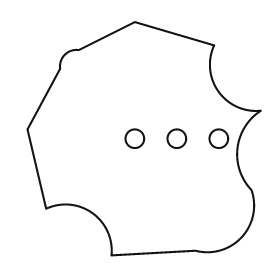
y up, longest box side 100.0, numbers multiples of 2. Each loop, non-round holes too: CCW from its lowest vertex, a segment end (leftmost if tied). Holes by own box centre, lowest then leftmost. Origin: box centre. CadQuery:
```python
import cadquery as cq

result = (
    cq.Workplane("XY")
    .moveTo(-14.0, -50.0)
    .lineTo(22.0, -48.0)
    .threePointArc((42.0, -42.0), (46.0, -22.0))
    .threePointArc((40.0, -4.0), (50.0, 12.0))
    .threePointArc((32.0, 20.0), (30.0, 40.0))
    .lineTo(-4.0, 50.0)
    .lineTo(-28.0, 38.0)
    .threePointArc((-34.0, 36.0), (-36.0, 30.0))
    .lineTo(-50.0, 4.0)
    .lineTo(-42.0, -30.0)
    .threePointArc((-22.0, -32.0), (-14.0, -50.0))
    .close()
    .moveTo(-4.0, 0.0)
    .circle(4.0)
    .moveTo(14.0, 0.0)
    .circle(4.0)
    .moveTo(32.0, 0.0)
    .circle(4.0)
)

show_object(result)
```